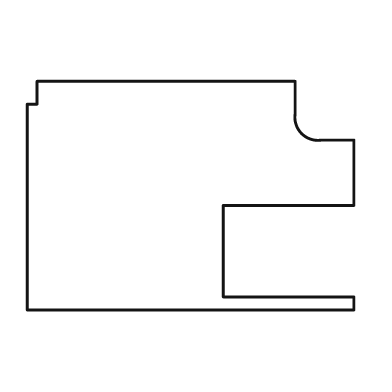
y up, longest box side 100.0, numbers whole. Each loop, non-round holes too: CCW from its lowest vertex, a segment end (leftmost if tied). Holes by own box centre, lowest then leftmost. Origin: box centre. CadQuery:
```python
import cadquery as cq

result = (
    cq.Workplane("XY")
    .moveTo(-50.0, -35.0)
    .lineTo(50.0, -35.0)
    .lineTo(50.0, -31.0)
    .lineTo(10.0, -31.0)
    .lineTo(10.0, -3.0)
    .lineTo(50.0, -3.0)
    .lineTo(50.0, 17.0)
    .lineTo(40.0, 17.0)
    .threePointArc((34.0, 19.0), (32.0, 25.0))
    .lineTo(32.0, 35.0)
    .lineTo(-47.0, 35.0)
    .lineTo(-47.0, 28.0)
    .lineTo(-50.0, 28.0)
    .close()
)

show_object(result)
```